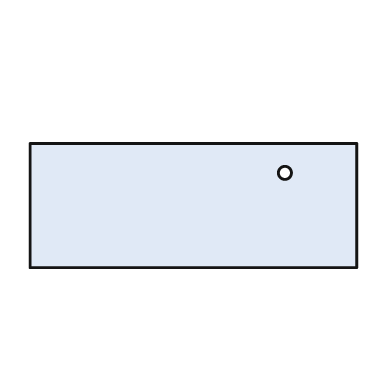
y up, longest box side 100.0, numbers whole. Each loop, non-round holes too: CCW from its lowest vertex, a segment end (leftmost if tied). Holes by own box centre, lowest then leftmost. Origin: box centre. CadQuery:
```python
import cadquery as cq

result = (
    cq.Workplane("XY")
    .moveTo(-50.0, -19.0)
    .lineTo(50.0, -19.0)
    .lineTo(50.0, 19.0)
    .lineTo(-50.0, 19.0)
    .close()
    .moveTo(28.0, 10.0)
    .circle(2.0)
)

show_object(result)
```